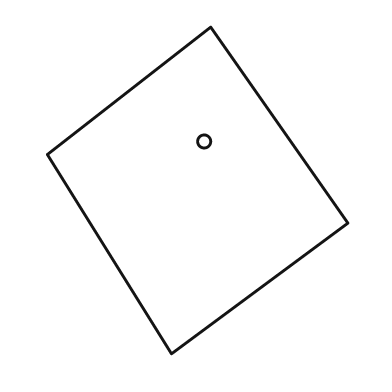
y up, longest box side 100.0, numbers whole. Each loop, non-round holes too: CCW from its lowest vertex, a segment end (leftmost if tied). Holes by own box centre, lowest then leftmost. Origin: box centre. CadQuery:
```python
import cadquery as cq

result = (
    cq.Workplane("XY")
    .moveTo(-8.0, -50.0)
    .lineTo(46.0, -10.0)
    .lineTo(4.0, 50.0)
    .lineTo(-46.0, 11.0)
    .close()
    .moveTo(2.0, 15.0)
    .circle(2.0)
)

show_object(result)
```